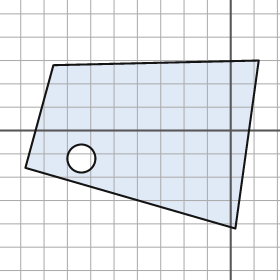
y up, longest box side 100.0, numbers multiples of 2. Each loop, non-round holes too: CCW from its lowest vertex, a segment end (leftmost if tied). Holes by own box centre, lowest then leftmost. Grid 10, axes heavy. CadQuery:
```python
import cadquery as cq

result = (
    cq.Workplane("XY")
    .moveTo(2.0, -42.0)
    .lineTo(12.0, 30.0)
    .lineTo(-76.0, 28.0)
    .lineTo(-88.0, -16.0)
    .close()
    .moveTo(-64.0, -12.0)
    .circle(6.0)
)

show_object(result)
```